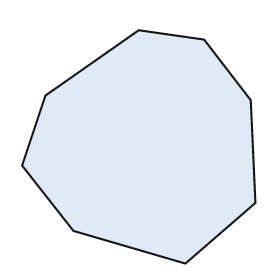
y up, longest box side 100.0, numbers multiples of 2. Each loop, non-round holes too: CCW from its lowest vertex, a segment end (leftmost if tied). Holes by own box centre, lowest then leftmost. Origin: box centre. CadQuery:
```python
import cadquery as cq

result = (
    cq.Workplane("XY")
    .moveTo(20.0, -50.0)
    .lineTo(50.0, -24.0)
    .lineTo(48.0, 20.0)
    .lineTo(28.0, 46.0)
    .lineTo(0.0, 50.0)
    .lineTo(-40.0, 22.0)
    .lineTo(-50.0, -8.0)
    .lineTo(-28.0, -36.0)
    .close()
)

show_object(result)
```